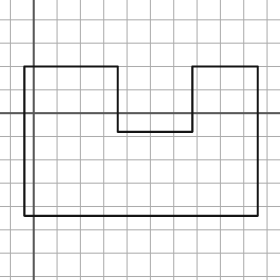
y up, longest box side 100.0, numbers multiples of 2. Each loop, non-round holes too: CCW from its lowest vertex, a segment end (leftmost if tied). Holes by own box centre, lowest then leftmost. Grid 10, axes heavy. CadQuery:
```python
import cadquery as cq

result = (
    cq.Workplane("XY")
    .moveTo(-4.0, -44.0)
    .lineTo(96.0, -44.0)
    .lineTo(96.0, 20.0)
    .lineTo(68.0, 20.0)
    .lineTo(68.0, -8.0)
    .lineTo(36.0, -8.0)
    .lineTo(36.0, 20.0)
    .lineTo(-4.0, 20.0)
    .close()
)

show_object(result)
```